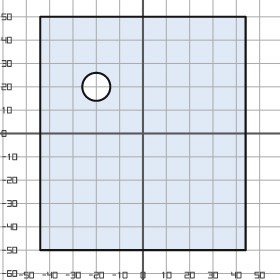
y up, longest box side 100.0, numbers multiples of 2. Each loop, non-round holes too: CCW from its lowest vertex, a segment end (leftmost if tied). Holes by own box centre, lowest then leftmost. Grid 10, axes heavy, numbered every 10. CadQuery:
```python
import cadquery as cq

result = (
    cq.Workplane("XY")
    .moveTo(-44.0, -50.0)
    .lineTo(44.0, -50.0)
    .lineTo(44.0, 50.0)
    .lineTo(-44.0, 50.0)
    .close()
    .moveTo(-20.0, 20.0)
    .circle(6.0)
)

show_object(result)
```